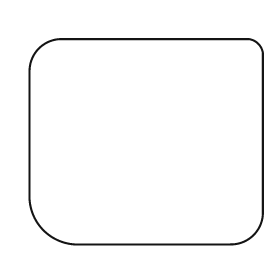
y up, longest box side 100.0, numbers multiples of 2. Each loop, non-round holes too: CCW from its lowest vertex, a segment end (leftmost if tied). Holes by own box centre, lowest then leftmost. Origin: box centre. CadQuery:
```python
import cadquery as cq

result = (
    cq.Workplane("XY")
    .moveTo(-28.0, -44.0)
    .lineTo(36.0, -44.0)
    .threePointArc((46.0, -40.0), (50.0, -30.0))
    .lineTo(50.0, 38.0)
    .threePointArc((48.0, 42.0), (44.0, 44.0))
    .lineTo(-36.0, 44.0)
    .threePointArc((-46.0, 40.0), (-50.0, 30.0))
    .lineTo(-50.0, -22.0)
    .threePointArc((-44.0, -38.0), (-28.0, -44.0))
    .close()
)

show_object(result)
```